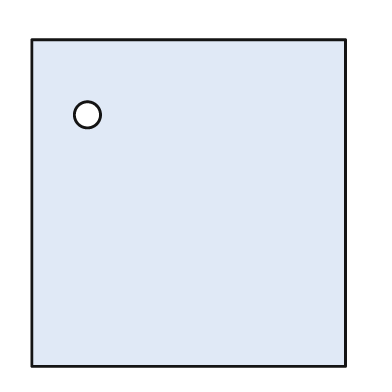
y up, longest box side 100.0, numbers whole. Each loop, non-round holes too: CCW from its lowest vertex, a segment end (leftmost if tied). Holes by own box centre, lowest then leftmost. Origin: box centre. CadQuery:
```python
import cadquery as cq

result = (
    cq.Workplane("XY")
    .moveTo(-48.0, -50.0)
    .lineTo(48.0, -50.0)
    .lineTo(48.0, 50.0)
    .lineTo(-48.0, 50.0)
    .close()
    .moveTo(-31.0, 27.0)
    .circle(4.0)
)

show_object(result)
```